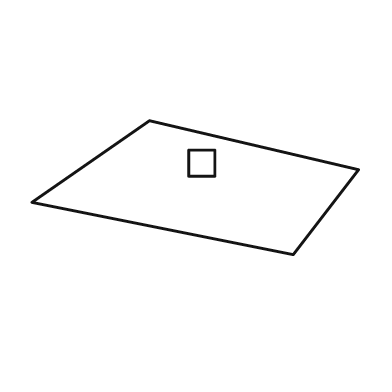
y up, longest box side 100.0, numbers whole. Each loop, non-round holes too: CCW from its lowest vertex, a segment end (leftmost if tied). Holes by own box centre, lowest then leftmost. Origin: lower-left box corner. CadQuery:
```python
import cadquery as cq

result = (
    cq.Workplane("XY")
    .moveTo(80.0, 0.0)
    .lineTo(100.0, 26.0)
    .lineTo(36.0, 41.0)
    .lineTo(0.0, 16.0)
    .close()
    .moveTo(48.0, 24.0)
    .lineTo(56.0, 24.0)
    .lineTo(56.0, 32.0)
    .lineTo(48.0, 32.0)
    .close()
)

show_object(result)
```